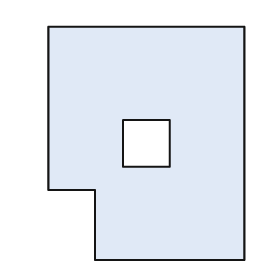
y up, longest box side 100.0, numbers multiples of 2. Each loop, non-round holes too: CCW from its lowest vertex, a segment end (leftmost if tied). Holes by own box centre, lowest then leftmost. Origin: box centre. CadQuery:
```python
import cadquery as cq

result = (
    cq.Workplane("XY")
    .moveTo(-22.0, -50.0)
    .lineTo(42.0, -50.0)
    .lineTo(42.0, 50.0)
    .lineTo(-42.0, 50.0)
    .lineTo(-42.0, -20.0)
    .lineTo(-22.0, -20.0)
    .close()
    .moveTo(-10.0, -10.0)
    .lineTo(10.0, -10.0)
    .lineTo(10.0, 10.0)
    .lineTo(-10.0, 10.0)
    .close()
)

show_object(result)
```